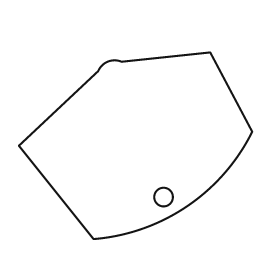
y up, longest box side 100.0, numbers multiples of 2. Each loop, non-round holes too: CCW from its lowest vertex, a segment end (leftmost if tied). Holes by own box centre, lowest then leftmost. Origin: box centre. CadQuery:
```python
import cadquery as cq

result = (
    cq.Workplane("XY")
    .moveTo(-18.0, -40.0)
    .threePointArc((22.0, -26.0), (50.0, 6.0))
    .lineTo(32.0, 40.0)
    .lineTo(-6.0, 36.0)
    .threePointArc((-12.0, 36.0), (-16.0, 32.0))
    .lineTo(-50.0, 0.0)
    .close()
    .moveTo(12.0, -22.0)
    .circle(4.0)
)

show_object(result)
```